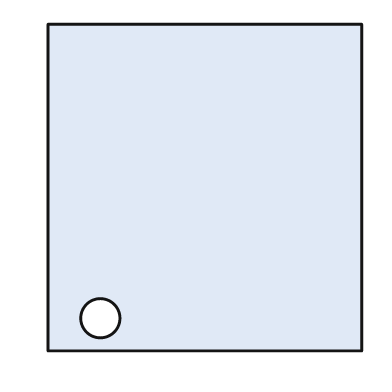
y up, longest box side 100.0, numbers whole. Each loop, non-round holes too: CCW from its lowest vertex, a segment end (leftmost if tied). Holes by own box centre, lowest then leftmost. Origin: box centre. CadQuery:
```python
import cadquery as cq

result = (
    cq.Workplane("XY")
    .moveTo(-48.0, -50.0)
    .lineTo(48.0, -50.0)
    .lineTo(48.0, 50.0)
    .lineTo(-48.0, 50.0)
    .close()
    .moveTo(-32.0, -40.0)
    .circle(6.0)
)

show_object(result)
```